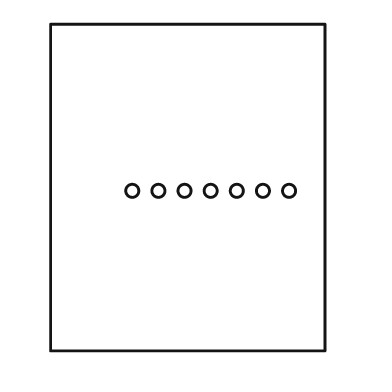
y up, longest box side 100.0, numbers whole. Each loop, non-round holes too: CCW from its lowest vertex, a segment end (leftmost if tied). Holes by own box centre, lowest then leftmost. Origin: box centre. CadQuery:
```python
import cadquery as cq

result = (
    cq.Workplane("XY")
    .moveTo(-42.0, -50.0)
    .lineTo(42.0, -50.0)
    .lineTo(42.0, 50.0)
    .lineTo(-42.0, 50.0)
    .close()
    .moveTo(-17.0, -1.0)
    .circle(2.0)
    .moveTo(-9.0, -1.0)
    .circle(2.0)
    .moveTo(-1.0, -1.0)
    .circle(2.0)
    .moveTo(7.0, -1.0)
    .circle(2.0)
    .moveTo(15.0, -1.0)
    .circle(2.0)
    .moveTo(23.0, -1.0)
    .circle(2.0)
    .moveTo(31.0, -1.0)
    .circle(2.0)
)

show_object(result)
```